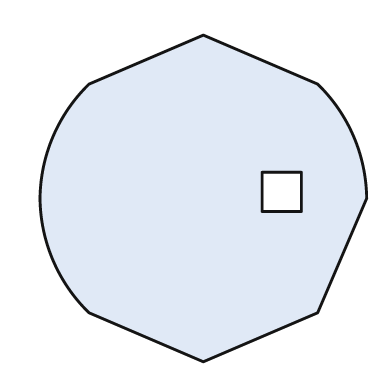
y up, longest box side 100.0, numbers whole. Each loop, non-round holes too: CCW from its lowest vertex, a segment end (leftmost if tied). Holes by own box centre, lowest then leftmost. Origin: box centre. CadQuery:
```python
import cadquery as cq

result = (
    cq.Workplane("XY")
    .moveTo(0.0, -50.0)
    .lineTo(35.0, -35.0)
    .lineTo(50.0, 0.0)
    .threePointArc((46.0, 19.0), (35.0, 35.0))
    .lineTo(0.0, 50.0)
    .lineTo(-35.0, 35.0)
    .threePointArc((-46.0, 19.0), (-50.0, 0.0))
    .threePointArc((-46.0, -19.0), (-35.0, -35.0))
    .close()
    .moveTo(18.0, -4.0)
    .lineTo(30.0, -4.0)
    .lineTo(30.0, 8.0)
    .lineTo(18.0, 8.0)
    .close()
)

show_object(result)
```